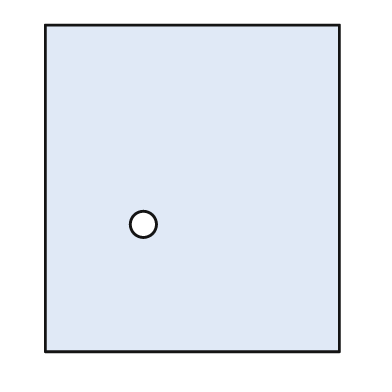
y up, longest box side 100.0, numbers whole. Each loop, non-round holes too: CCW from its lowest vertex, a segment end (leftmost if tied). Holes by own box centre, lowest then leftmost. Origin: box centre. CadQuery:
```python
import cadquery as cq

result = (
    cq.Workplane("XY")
    .moveTo(-45.0, -50.0)
    .lineTo(45.0, -50.0)
    .lineTo(45.0, 50.0)
    .lineTo(-45.0, 50.0)
    .close()
    .moveTo(-15.0, -11.0)
    .circle(4.0)
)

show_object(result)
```